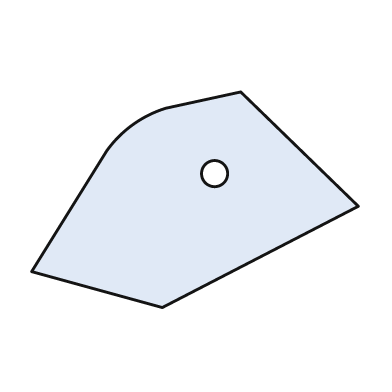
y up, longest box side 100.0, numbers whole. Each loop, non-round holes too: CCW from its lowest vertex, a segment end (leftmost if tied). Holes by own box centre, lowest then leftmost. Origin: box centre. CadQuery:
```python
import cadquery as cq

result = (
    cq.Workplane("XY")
    .moveTo(-10.0, -33.0)
    .lineTo(50.0, -2.0)
    .lineTo(14.0, 33.0)
    .lineTo(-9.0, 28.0)
    .threePointArc((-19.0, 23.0), (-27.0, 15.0))
    .lineTo(-50.0, -22.0)
    .close()
    .moveTo(6.0, 8.0)
    .circle(4.0)
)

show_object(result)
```